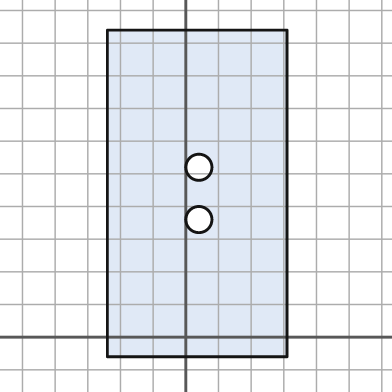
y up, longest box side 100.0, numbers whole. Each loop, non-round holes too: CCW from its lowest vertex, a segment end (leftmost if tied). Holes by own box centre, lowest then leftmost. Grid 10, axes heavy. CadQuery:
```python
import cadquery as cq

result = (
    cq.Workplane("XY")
    .moveTo(-24.0, -6.0)
    .lineTo(31.0, -6.0)
    .lineTo(31.0, 94.0)
    .lineTo(-24.0, 94.0)
    .close()
    .moveTo(4.0, 36.0)
    .circle(4.0)
    .moveTo(4.0, 52.0)
    .circle(4.0)
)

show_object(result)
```